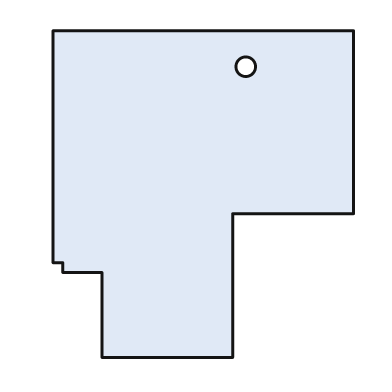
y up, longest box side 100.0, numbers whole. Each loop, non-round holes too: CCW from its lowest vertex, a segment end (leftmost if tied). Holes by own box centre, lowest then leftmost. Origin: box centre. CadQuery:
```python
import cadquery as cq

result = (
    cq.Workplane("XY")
    .moveTo(-31.0, -50.0)
    .lineTo(9.0, -50.0)
    .lineTo(9.0, -6.0)
    .lineTo(46.0, -6.0)
    .lineTo(46.0, 50.0)
    .lineTo(-46.0, 50.0)
    .lineTo(-46.0, -21.0)
    .lineTo(-43.0, -21.0)
    .lineTo(-43.0, -24.0)
    .lineTo(-31.0, -24.0)
    .close()
    .moveTo(13.0, 39.0)
    .circle(3.0)
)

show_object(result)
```